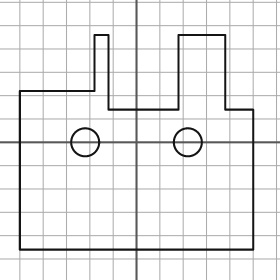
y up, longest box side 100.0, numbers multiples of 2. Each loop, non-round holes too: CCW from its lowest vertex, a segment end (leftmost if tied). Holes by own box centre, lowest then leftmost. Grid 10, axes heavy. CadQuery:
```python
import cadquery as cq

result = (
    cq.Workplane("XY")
    .moveTo(-50.0, -46.0)
    .lineTo(50.0, -46.0)
    .lineTo(50.0, 14.0)
    .lineTo(38.0, 14.0)
    .lineTo(38.0, 46.0)
    .lineTo(18.0, 46.0)
    .lineTo(18.0, 14.0)
    .lineTo(-12.0, 14.0)
    .lineTo(-12.0, 46.0)
    .lineTo(-18.0, 46.0)
    .lineTo(-18.0, 22.0)
    .lineTo(-50.0, 22.0)
    .close()
    .moveTo(-22.0, 0.0)
    .circle(6.0)
    .moveTo(22.0, 0.0)
    .circle(6.0)
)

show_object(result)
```